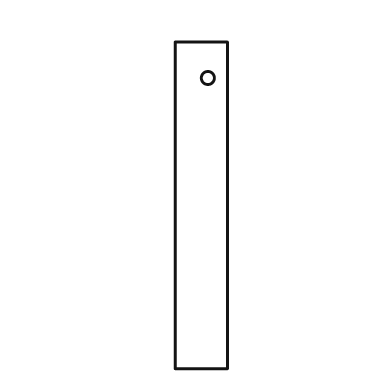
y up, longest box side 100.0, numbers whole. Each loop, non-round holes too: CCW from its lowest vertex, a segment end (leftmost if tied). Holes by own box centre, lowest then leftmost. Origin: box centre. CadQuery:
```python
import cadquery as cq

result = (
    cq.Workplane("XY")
    .moveTo(-8.0, -50.0)
    .lineTo(8.0, -50.0)
    .lineTo(8.0, 50.0)
    .lineTo(-8.0, 50.0)
    .close()
    .moveTo(2.0, 39.0)
    .circle(2.0)
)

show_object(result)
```